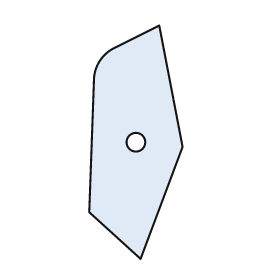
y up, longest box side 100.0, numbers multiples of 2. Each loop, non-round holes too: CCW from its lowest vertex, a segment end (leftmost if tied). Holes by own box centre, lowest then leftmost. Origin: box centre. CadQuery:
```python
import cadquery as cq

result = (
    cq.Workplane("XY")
    .moveTo(2.0, -50.0)
    .lineTo(20.0, -2.0)
    .lineTo(10.0, 50.0)
    .lineTo(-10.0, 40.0)
    .threePointArc((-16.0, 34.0), (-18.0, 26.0))
    .lineTo(-20.0, -30.0)
    .close()
    .moveTo(0.0, 0.0)
    .circle(4.0)
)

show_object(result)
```